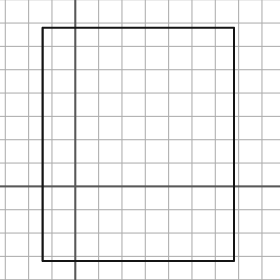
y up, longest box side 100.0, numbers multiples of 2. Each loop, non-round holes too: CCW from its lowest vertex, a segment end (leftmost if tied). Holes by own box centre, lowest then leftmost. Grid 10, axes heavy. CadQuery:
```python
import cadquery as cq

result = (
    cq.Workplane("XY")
    .moveTo(-14.0, -32.0)
    .lineTo(68.0, -32.0)
    .lineTo(68.0, 68.0)
    .lineTo(-14.0, 68.0)
    .close()
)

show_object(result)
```